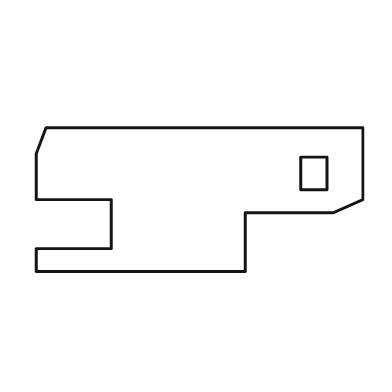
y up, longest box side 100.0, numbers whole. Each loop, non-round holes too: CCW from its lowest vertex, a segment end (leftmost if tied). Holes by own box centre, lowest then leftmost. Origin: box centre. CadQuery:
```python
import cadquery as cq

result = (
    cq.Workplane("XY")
    .moveTo(-50.0, -22.0)
    .lineTo(14.0, -22.0)
    .lineTo(14.0, -4.0)
    .lineTo(41.0, -4.0)
    .lineTo(50.0, 0.0)
    .lineTo(50.0, 22.0)
    .lineTo(-47.0, 22.0)
    .lineTo(-50.0, 14.0)
    .lineTo(-50.0, 0.0)
    .lineTo(-27.0, 0.0)
    .lineTo(-27.0, -15.0)
    .lineTo(-50.0, -15.0)
    .close()
    .moveTo(31.0, 3.0)
    .lineTo(39.0, 3.0)
    .lineTo(39.0, 13.0)
    .lineTo(31.0, 13.0)
    .close()
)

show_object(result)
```